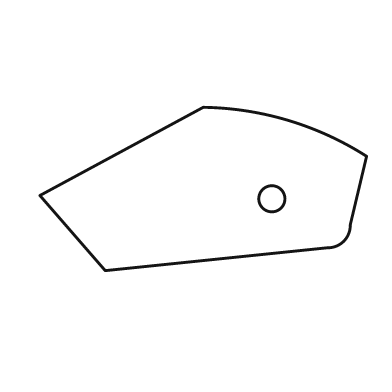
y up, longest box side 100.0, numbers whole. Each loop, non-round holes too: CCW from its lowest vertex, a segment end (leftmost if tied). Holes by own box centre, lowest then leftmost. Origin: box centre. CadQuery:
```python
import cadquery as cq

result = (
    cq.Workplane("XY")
    .moveTo(-30.0, -25.0)
    .lineTo(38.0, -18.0)
    .threePointArc((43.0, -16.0), (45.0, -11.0))
    .lineTo(50.0, 10.0)
    .threePointArc((26.0, 21.0), (0.0, 25.0))
    .lineTo(-50.0, -2.0)
    .close()
    .moveTo(21.0, -3.0)
    .circle(4.0)
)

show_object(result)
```